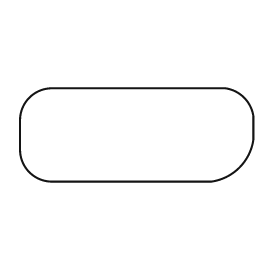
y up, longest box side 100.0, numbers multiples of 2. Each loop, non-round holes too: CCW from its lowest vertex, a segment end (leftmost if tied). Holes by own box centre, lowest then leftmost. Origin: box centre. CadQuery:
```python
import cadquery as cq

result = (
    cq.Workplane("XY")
    .moveTo(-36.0, -20.0)
    .lineTo(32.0, -20.0)
    .threePointArc((44.0, -14.0), (50.0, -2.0))
    .lineTo(50.0, 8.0)
    .threePointArc((46.0, 16.0), (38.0, 20.0))
    .lineTo(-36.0, 20.0)
    .threePointArc((-46.0, 16.0), (-50.0, 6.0))
    .lineTo(-50.0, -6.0)
    .threePointArc((-46.0, -16.0), (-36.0, -20.0))
    .close()
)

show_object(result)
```